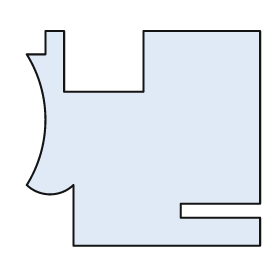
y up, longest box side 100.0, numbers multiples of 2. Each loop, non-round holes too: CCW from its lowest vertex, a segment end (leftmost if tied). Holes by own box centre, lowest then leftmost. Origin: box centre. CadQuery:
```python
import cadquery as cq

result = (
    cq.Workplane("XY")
    .moveTo(-30.0, -46.0)
    .lineTo(50.0, -46.0)
    .lineTo(50.0, -34.0)
    .lineTo(16.0, -34.0)
    .lineTo(16.0, -28.0)
    .lineTo(50.0, -28.0)
    .lineTo(50.0, 46.0)
    .lineTo(0.0, 46.0)
    .lineTo(0.0, 20.0)
    .lineTo(-34.0, 20.0)
    .lineTo(-34.0, 46.0)
    .lineTo(-42.0, 46.0)
    .lineTo(-42.0, 36.0)
    .lineTo(-50.0, 36.0)
    .threePointArc((-42.0, 8.0), (-50.0, -20.0))
    .threePointArc((-40.0, -24.0), (-30.0, -20.0))
    .close()
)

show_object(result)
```